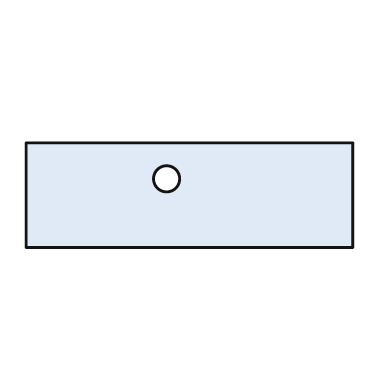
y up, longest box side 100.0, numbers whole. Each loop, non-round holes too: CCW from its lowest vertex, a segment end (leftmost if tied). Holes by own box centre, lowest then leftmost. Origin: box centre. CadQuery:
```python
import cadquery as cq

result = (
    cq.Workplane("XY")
    .moveTo(-50.0, -16.0)
    .lineTo(50.0, -16.0)
    .lineTo(50.0, 16.0)
    .lineTo(-50.0, 16.0)
    .close()
    .moveTo(-7.0, 5.0)
    .circle(4.0)
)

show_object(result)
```